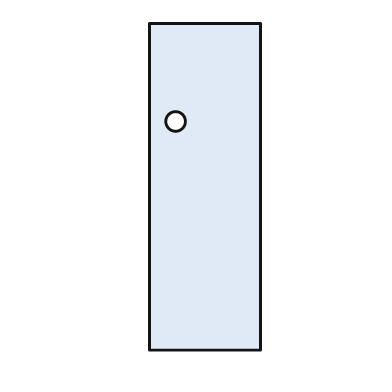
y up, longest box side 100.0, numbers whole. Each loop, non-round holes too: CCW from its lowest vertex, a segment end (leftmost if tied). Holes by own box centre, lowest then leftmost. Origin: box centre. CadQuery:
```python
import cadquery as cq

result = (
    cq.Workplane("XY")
    .moveTo(-17.0, -50.0)
    .lineTo(17.0, -50.0)
    .lineTo(17.0, 50.0)
    .lineTo(-17.0, 50.0)
    .close()
    .moveTo(-9.0, 20.0)
    .circle(3.0)
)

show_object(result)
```